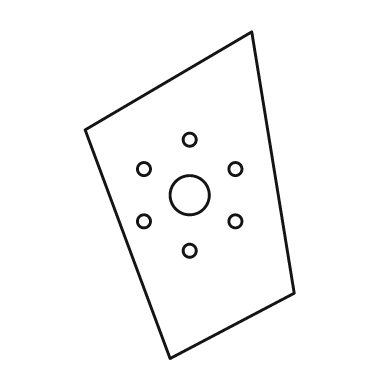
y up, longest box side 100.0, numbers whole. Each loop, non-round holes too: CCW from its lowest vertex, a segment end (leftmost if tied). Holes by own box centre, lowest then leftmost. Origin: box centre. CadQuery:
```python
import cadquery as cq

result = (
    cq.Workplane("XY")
    .moveTo(-6.0, -50.0)
    .lineTo(32.0, -30.0)
    .lineTo(19.0, 50.0)
    .lineTo(-32.0, 20.0)
    .close()
    .moveTo(0.0, -17.0)
    .circle(2.0)
    .moveTo(-14.0, -8.0)
    .circle(2.0)
    .moveTo(14.0, -8.0)
    .circle(2.0)
    .moveTo(0.0, 0.0)
    .circle(6.0)
    .moveTo(-14.0, 8.0)
    .circle(2.0)
    .moveTo(14.0, 8.0)
    .circle(2.0)
    .moveTo(0.0, 17.0)
    .circle(2.0)
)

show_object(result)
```